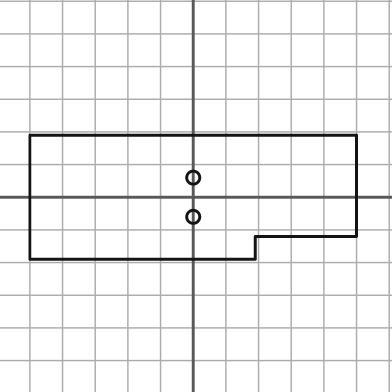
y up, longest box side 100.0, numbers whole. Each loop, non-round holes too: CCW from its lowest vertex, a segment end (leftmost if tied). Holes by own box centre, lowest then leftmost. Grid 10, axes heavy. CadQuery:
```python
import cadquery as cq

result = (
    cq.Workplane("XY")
    .moveTo(-50.0, -19.0)
    .lineTo(19.0, -19.0)
    .lineTo(19.0, -12.0)
    .lineTo(50.0, -12.0)
    .lineTo(50.0, 19.0)
    .lineTo(-50.0, 19.0)
    .close()
    .moveTo(0.0, -6.0)
    .circle(2.0)
    .moveTo(0.0, 6.0)
    .circle(2.0)
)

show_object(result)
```